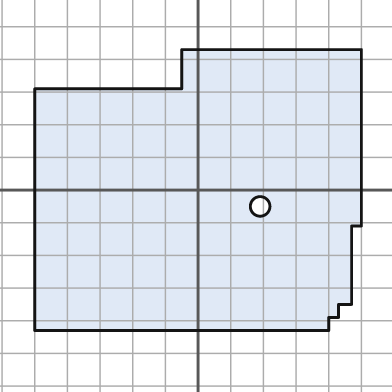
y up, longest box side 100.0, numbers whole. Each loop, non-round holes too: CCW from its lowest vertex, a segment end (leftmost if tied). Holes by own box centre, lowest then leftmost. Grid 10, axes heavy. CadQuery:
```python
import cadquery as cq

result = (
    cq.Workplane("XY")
    .moveTo(-50.0, -43.0)
    .lineTo(40.0, -43.0)
    .lineTo(40.0, -39.0)
    .lineTo(43.0, -39.0)
    .lineTo(43.0, -35.0)
    .lineTo(47.0, -35.0)
    .lineTo(47.0, -11.0)
    .lineTo(50.0, -11.0)
    .lineTo(50.0, 43.0)
    .lineTo(-5.0, 43.0)
    .lineTo(-5.0, 31.0)
    .lineTo(-50.0, 31.0)
    .close()
    .moveTo(19.0, -5.0)
    .circle(3.0)
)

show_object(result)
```